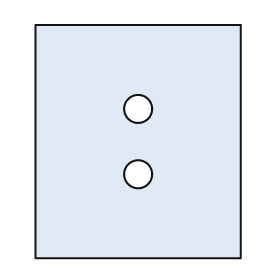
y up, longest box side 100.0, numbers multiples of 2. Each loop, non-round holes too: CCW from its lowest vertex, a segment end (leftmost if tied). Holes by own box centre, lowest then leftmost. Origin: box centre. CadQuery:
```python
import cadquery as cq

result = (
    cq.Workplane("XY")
    .moveTo(-44.0, -50.0)
    .lineTo(44.0, -50.0)
    .lineTo(44.0, 50.0)
    .lineTo(-44.0, 50.0)
    .close()
    .moveTo(0.0, -14.0)
    .circle(6.0)
    .moveTo(0.0, 14.0)
    .circle(6.0)
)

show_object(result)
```